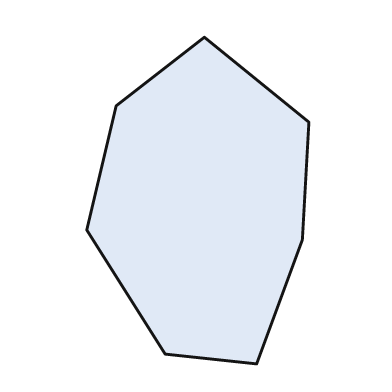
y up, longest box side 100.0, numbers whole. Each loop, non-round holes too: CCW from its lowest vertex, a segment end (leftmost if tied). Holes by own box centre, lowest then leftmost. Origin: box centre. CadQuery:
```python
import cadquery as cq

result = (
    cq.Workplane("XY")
    .moveTo(18.0, -50.0)
    .lineTo(32.0, -12.0)
    .lineTo(34.0, 24.0)
    .lineTo(2.0, 50.0)
    .lineTo(-25.0, 29.0)
    .lineTo(-34.0, -9.0)
    .lineTo(-10.0, -47.0)
    .close()
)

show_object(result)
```